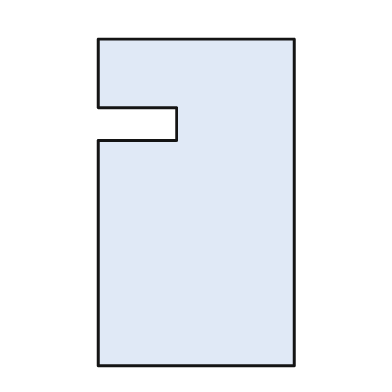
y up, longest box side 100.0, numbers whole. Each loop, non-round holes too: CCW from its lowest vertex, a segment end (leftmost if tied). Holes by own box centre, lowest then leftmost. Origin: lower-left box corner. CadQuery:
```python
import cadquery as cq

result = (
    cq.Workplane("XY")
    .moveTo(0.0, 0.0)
    .lineTo(60.0, 0.0)
    .lineTo(60.0, 100.0)
    .lineTo(0.0, 100.0)
    .lineTo(0.0, 79.0)
    .lineTo(24.0, 79.0)
    .lineTo(24.0, 69.0)
    .lineTo(0.0, 69.0)
    .close()
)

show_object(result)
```